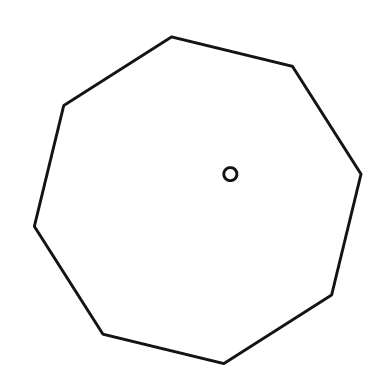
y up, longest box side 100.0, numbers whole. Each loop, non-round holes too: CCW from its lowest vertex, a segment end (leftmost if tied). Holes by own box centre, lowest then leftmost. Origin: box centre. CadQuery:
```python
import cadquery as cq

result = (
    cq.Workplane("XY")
    .moveTo(8.0, -50.0)
    .lineTo(41.0, -29.0)
    .lineTo(50.0, 8.0)
    .lineTo(29.0, 41.0)
    .lineTo(-8.0, 50.0)
    .lineTo(-41.0, 29.0)
    .lineTo(-50.0, -8.0)
    .lineTo(-29.0, -41.0)
    .close()
    .moveTo(10.0, 8.0)
    .circle(2.0)
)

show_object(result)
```